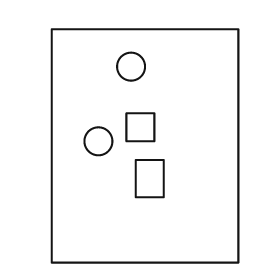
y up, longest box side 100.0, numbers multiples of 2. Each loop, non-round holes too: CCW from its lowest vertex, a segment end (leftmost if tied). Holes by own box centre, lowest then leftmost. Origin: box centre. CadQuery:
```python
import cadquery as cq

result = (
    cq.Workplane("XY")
    .moveTo(-40.0, -50.0)
    .lineTo(40.0, -50.0)
    .lineTo(40.0, 50.0)
    .lineTo(-40.0, 50.0)
    .close()
    .moveTo(-4.0, -22.0)
    .lineTo(8.0, -22.0)
    .lineTo(8.0, -6.0)
    .lineTo(-4.0, -6.0)
    .close()
    .moveTo(-20.0, 2.0)
    .circle(6.0)
    .moveTo(-8.0, 2.0)
    .lineTo(4.0, 2.0)
    .lineTo(4.0, 14.0)
    .lineTo(-8.0, 14.0)
    .close()
    .moveTo(-6.0, 34.0)
    .circle(6.0)
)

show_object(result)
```